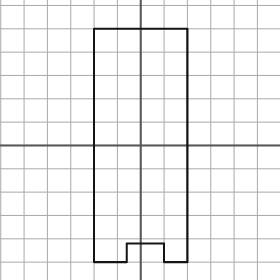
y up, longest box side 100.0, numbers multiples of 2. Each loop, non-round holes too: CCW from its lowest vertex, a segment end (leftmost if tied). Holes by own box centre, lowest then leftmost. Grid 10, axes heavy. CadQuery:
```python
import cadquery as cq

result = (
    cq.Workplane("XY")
    .moveTo(-20.0, -50.0)
    .lineTo(-6.0, -50.0)
    .lineTo(-6.0, -42.0)
    .lineTo(10.0, -42.0)
    .lineTo(10.0, -50.0)
    .lineTo(20.0, -50.0)
    .lineTo(20.0, 50.0)
    .lineTo(-20.0, 50.0)
    .close()
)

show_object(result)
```